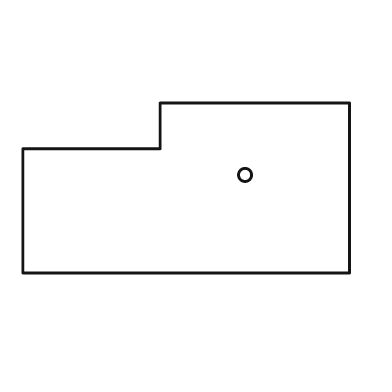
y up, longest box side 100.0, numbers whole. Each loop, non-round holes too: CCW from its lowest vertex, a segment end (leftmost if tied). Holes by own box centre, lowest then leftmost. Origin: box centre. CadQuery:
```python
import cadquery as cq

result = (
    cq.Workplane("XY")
    .moveTo(-50.0, -26.0)
    .lineTo(50.0, -26.0)
    .lineTo(50.0, 26.0)
    .lineTo(-8.0, 26.0)
    .lineTo(-8.0, 12.0)
    .lineTo(-50.0, 12.0)
    .close()
    .moveTo(18.0, 4.0)
    .circle(2.0)
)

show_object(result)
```